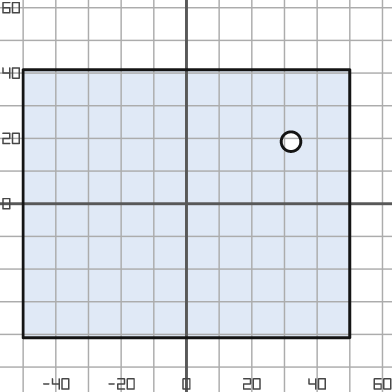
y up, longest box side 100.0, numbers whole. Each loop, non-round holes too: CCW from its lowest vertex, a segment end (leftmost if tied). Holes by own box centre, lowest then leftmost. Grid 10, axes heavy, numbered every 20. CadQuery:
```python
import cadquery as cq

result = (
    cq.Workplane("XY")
    .moveTo(-50.0, -41.0)
    .lineTo(50.0, -41.0)
    .lineTo(50.0, 41.0)
    .lineTo(-50.0, 41.0)
    .close()
    .moveTo(32.0, 19.0)
    .circle(3.0)
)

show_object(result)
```